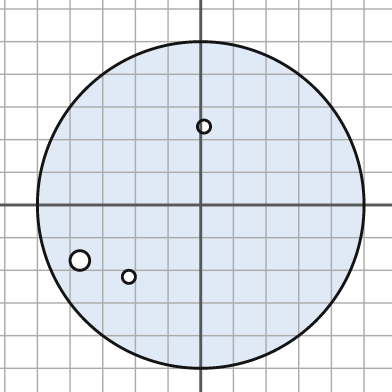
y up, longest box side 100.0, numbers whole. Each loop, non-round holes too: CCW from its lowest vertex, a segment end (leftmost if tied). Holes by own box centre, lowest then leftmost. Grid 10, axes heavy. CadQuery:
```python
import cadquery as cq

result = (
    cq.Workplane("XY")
    .moveTo(0.0, 0.0)
    .circle(50.0)
    .moveTo(-22.0, -22.0)
    .circle(2.0)
    .moveTo(-37.0, -17.0)
    .circle(3.0)
    .moveTo(1.0, 24.0)
    .circle(2.0)
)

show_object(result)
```